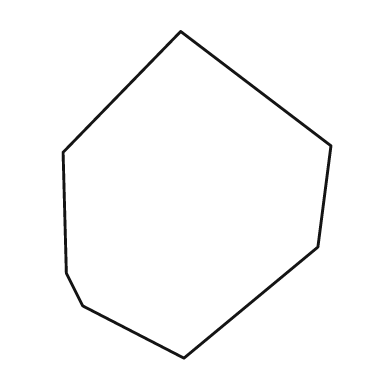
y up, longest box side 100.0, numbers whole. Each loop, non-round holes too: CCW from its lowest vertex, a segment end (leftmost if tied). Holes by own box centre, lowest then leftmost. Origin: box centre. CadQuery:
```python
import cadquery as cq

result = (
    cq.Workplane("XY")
    .moveTo(-4.0, -50.0)
    .lineTo(37.0, -16.0)
    .lineTo(41.0, 15.0)
    .lineTo(-5.0, 50.0)
    .lineTo(-41.0, 13.0)
    .lineTo(-40.0, -24.0)
    .lineTo(-35.0, -34.0)
    .close()
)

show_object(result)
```